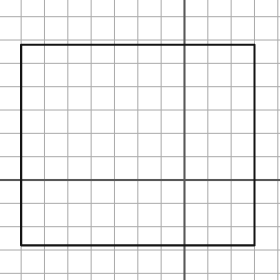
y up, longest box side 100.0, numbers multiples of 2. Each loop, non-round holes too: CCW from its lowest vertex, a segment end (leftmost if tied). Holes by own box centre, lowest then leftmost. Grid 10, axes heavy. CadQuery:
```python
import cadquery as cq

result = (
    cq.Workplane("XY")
    .moveTo(-70.0, -28.0)
    .lineTo(30.0, -28.0)
    .lineTo(30.0, 58.0)
    .lineTo(-70.0, 58.0)
    .close()
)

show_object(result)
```